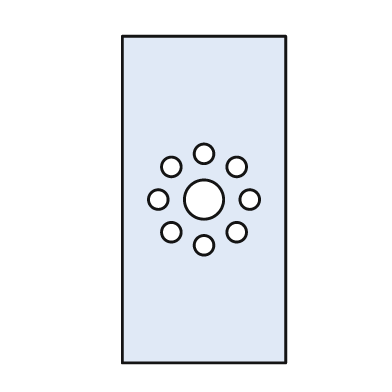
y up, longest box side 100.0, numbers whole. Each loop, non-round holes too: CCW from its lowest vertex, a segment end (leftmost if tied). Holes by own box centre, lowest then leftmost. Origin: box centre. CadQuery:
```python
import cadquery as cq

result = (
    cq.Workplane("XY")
    .moveTo(-25.0, -50.0)
    .lineTo(25.0, -50.0)
    .lineTo(25.0, 50.0)
    .lineTo(-25.0, 50.0)
    .close()
    .moveTo(0.0, -14.0)
    .circle(3.0)
    .moveTo(-10.0, -10.0)
    .circle(3.0)
    .moveTo(10.0, -10.0)
    .circle(3.0)
    .moveTo(-14.0, 0.0)
    .circle(3.0)
    .moveTo(0.0, 0.0)
    .circle(6.0)
    .moveTo(14.0, 0.0)
    .circle(3.0)
    .moveTo(-10.0, 10.0)
    .circle(3.0)
    .moveTo(10.0, 10.0)
    .circle(3.0)
    .moveTo(0.0, 14.0)
    .circle(3.0)
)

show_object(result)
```